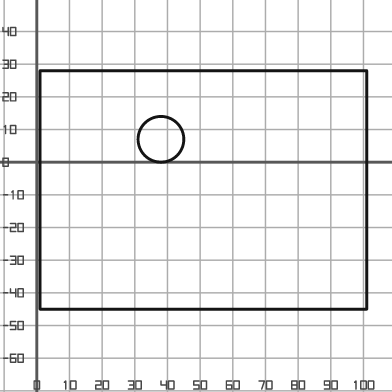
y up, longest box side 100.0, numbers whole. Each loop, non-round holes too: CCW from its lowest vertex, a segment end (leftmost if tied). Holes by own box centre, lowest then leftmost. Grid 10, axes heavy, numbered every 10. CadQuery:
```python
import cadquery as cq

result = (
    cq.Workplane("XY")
    .moveTo(1.0, -45.0)
    .lineTo(101.0, -45.0)
    .lineTo(101.0, 28.0)
    .lineTo(1.0, 28.0)
    .close()
    .moveTo(38.0, 7.0)
    .circle(7.0)
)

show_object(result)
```